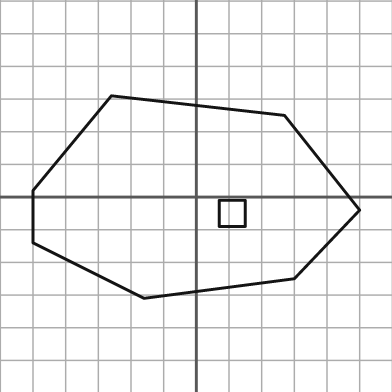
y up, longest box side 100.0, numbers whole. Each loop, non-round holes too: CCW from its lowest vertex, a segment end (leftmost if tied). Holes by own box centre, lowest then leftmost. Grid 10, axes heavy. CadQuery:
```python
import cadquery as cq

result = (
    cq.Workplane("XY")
    .moveTo(-16.0, -31.0)
    .lineTo(30.0, -25.0)
    .lineTo(50.0, -4.0)
    .lineTo(27.0, 25.0)
    .lineTo(-26.0, 31.0)
    .lineTo(-50.0, 2.0)
    .lineTo(-50.0, -14.0)
    .close()
    .moveTo(7.0, -9.0)
    .lineTo(15.0, -9.0)
    .lineTo(15.0, -1.0)
    .lineTo(7.0, -1.0)
    .close()
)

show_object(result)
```